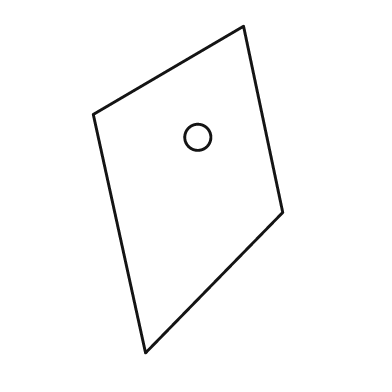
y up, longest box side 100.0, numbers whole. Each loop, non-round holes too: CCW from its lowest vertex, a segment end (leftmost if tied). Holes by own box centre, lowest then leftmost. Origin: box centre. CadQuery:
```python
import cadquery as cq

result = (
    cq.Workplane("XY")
    .moveTo(-13.0, -50.0)
    .lineTo(29.0, -7.0)
    .lineTo(17.0, 50.0)
    .lineTo(-29.0, 23.0)
    .close()
    .moveTo(3.0, 16.0)
    .circle(4.0)
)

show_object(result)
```